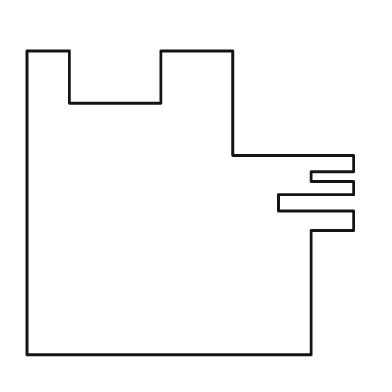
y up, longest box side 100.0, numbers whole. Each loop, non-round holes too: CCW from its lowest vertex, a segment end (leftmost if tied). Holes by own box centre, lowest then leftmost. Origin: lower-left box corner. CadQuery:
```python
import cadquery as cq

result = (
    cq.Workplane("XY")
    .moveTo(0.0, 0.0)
    .lineTo(87.0, 0.0)
    .lineTo(87.0, 38.0)
    .lineTo(100.0, 38.0)
    .lineTo(100.0, 44.0)
    .lineTo(77.0, 44.0)
    .lineTo(77.0, 49.0)
    .lineTo(100.0, 49.0)
    .lineTo(100.0, 53.0)
    .lineTo(87.0, 53.0)
    .lineTo(87.0, 56.0)
    .lineTo(100.0, 56.0)
    .lineTo(100.0, 61.0)
    .lineTo(63.0, 61.0)
    .lineTo(63.0, 93.0)
    .lineTo(41.0, 93.0)
    .lineTo(41.0, 77.0)
    .lineTo(13.0, 77.0)
    .lineTo(13.0, 93.0)
    .lineTo(0.0, 93.0)
    .close()
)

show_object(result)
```